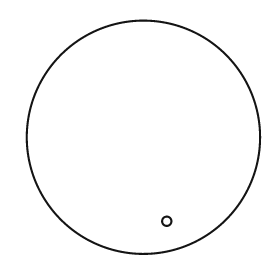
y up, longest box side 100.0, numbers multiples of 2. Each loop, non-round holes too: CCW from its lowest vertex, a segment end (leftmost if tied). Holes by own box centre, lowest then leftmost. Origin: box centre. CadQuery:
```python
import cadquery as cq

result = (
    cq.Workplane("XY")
    .moveTo(0.0, 0.0)
    .circle(50.0)
    .moveTo(10.0, -36.0)
    .circle(2.0)
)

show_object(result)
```